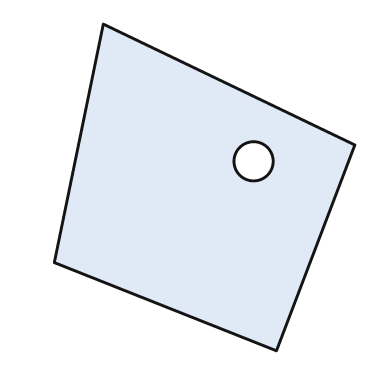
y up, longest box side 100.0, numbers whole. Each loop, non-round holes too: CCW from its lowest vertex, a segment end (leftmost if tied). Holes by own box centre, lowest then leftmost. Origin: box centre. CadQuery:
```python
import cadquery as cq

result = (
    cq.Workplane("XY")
    .moveTo(22.0, -50.0)
    .lineTo(46.0, 13.0)
    .lineTo(-31.0, 50.0)
    .lineTo(-46.0, -23.0)
    .close()
    .moveTo(15.0, 8.0)
    .circle(6.0)
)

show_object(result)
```